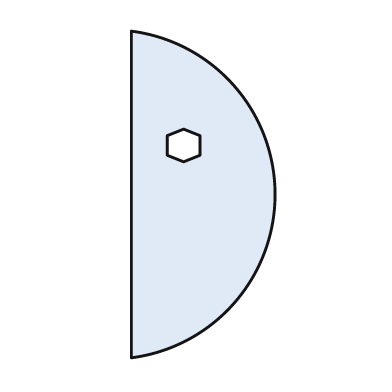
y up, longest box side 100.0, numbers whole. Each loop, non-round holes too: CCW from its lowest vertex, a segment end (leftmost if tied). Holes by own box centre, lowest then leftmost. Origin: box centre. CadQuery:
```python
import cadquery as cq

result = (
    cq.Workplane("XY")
    .moveTo(-22.0, -50.0)
    .threePointArc((22.0, 0.0), (-22.0, 50.0))
    .close()
    .moveTo(-6.0, 10.0)
    .lineTo(-1.0, 12.0)
    .lineTo(-1.0, 18.0)
    .lineTo(-6.0, 20.0)
    .lineTo(-11.0, 18.0)
    .lineTo(-11.0, 12.0)
    .close()
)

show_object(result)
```